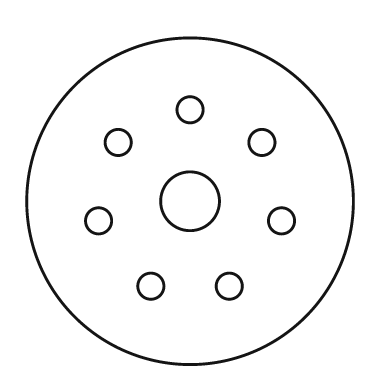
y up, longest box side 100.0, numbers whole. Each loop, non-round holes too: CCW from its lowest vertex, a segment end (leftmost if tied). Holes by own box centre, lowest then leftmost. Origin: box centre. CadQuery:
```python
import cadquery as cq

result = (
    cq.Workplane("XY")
    .moveTo(0.0, 0.0)
    .circle(50.0)
    .moveTo(-12.0, -26.0)
    .circle(4.0)
    .moveTo(12.0, -26.0)
    .circle(4.0)
    .moveTo(-28.0, -6.0)
    .circle(4.0)
    .moveTo(28.0, -6.0)
    .circle(4.0)
    .moveTo(0.0, 0.0)
    .circle(9.0)
    .moveTo(-22.0, 18.0)
    .circle(4.0)
    .moveTo(22.0, 18.0)
    .circle(4.0)
    .moveTo(0.0, 28.0)
    .circle(4.0)
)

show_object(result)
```